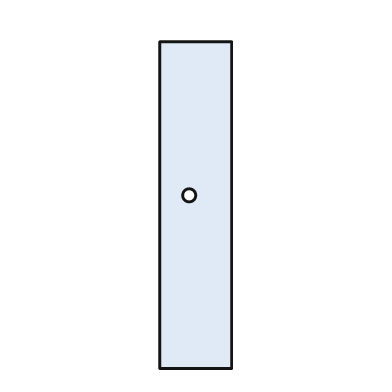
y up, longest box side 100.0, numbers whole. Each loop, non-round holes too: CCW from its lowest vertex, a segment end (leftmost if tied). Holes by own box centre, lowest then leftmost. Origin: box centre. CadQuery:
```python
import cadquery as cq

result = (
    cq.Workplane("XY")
    .moveTo(-11.0, -50.0)
    .lineTo(11.0, -50.0)
    .lineTo(11.0, 50.0)
    .lineTo(-11.0, 50.0)
    .close()
    .moveTo(-2.0, 3.0)
    .circle(2.0)
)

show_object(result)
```